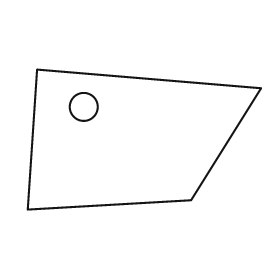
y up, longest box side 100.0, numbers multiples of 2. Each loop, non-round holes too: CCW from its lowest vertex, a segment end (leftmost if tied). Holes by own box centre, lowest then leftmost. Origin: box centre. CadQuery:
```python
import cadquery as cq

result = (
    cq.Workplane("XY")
    .moveTo(-50.0, -30.0)
    .lineTo(20.0, -26.0)
    .lineTo(50.0, 22.0)
    .lineTo(-46.0, 30.0)
    .close()
    .moveTo(-26.0, 14.0)
    .circle(6.0)
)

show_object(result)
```